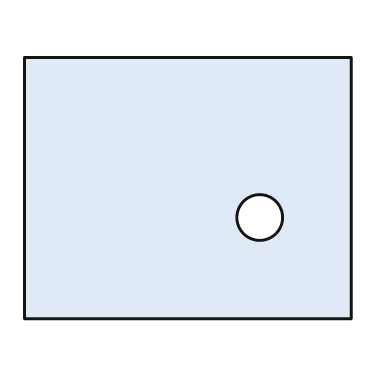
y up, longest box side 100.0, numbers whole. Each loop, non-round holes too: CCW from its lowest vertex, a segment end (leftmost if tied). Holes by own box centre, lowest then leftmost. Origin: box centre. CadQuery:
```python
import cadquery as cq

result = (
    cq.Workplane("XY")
    .moveTo(-50.0, -40.0)
    .lineTo(50.0, -40.0)
    .lineTo(50.0, 40.0)
    .lineTo(-50.0, 40.0)
    .close()
    .moveTo(22.0, -9.0)
    .circle(7.0)
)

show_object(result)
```